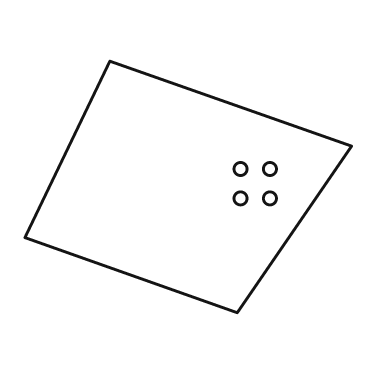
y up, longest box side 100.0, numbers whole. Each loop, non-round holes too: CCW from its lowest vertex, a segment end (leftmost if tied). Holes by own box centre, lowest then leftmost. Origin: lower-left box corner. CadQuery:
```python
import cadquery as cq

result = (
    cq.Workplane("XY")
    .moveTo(65.0, 0.0)
    .lineTo(100.0, 51.0)
    .lineTo(26.0, 77.0)
    .lineTo(0.0, 23.0)
    .close()
    .moveTo(66.0, 35.0)
    .circle(2.0)
    .moveTo(75.0, 35.0)
    .circle(2.0)
    .moveTo(66.0, 44.0)
    .circle(2.0)
    .moveTo(75.0, 44.0)
    .circle(2.0)
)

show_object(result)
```